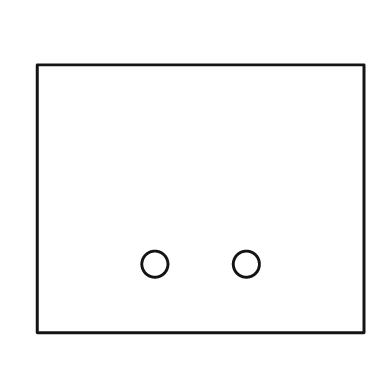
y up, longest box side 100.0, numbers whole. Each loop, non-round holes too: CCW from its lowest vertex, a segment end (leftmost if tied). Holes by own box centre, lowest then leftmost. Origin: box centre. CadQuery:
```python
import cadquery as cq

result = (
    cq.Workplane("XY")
    .moveTo(-50.0, -41.0)
    .lineTo(50.0, -41.0)
    .lineTo(50.0, 41.0)
    .lineTo(-50.0, 41.0)
    .close()
    .moveTo(-14.0, -20.0)
    .circle(4.0)
    .moveTo(14.0, -20.0)
    .circle(4.0)
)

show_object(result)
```